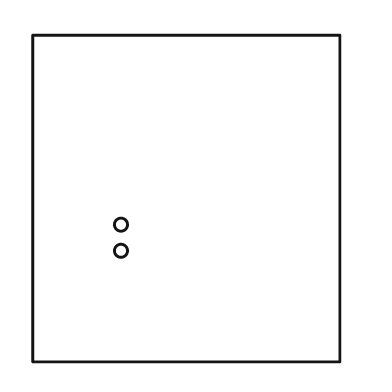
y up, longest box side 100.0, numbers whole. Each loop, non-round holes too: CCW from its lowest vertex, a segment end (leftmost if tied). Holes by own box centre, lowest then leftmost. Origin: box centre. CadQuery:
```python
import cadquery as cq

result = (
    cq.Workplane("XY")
    .moveTo(-47.0, -50.0)
    .lineTo(47.0, -50.0)
    .lineTo(47.0, 50.0)
    .lineTo(-47.0, 50.0)
    .close()
    .moveTo(-20.0, -16.0)
    .circle(2.0)
    .moveTo(-20.0, -8.0)
    .circle(2.0)
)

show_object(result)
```